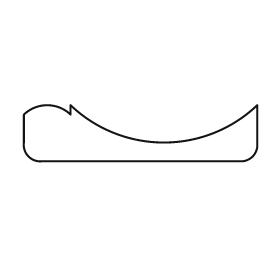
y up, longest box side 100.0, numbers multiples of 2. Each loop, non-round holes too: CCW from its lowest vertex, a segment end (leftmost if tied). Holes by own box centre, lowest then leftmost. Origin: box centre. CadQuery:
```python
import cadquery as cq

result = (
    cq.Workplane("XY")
    .moveTo(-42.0, -12.0)
    .lineTo(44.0, -12.0)
    .threePointArc((48.0, -10.0), (50.0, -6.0))
    .lineTo(50.0, 12.0)
    .threePointArc((10.0, -4.0), (-30.0, 12.0))
    .lineTo(-30.0, 8.0)
    .threePointArc((-40.0, 12.0), (-50.0, 8.0))
    .lineTo(-50.0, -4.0)
    .threePointArc((-48.0, -10.0), (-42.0, -12.0))
    .close()
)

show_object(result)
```